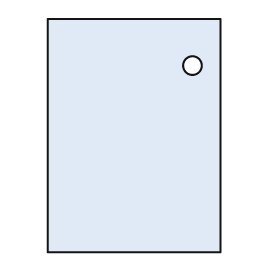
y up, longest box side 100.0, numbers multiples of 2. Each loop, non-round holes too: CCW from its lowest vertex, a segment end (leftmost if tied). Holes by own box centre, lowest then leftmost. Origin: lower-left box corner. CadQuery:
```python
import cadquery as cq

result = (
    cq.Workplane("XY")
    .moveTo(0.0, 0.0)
    .lineTo(74.0, 0.0)
    .lineTo(74.0, 100.0)
    .lineTo(0.0, 100.0)
    .close()
    .moveTo(62.0, 80.0)
    .circle(4.0)
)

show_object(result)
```